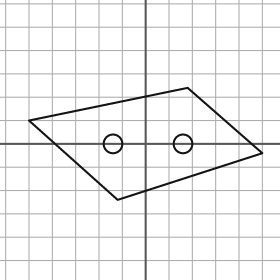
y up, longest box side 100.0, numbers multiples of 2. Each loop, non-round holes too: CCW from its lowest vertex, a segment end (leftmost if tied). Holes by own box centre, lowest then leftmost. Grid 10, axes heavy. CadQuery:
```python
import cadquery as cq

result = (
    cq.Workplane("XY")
    .moveTo(-12.0, -24.0)
    .lineTo(50.0, -4.0)
    .lineTo(18.0, 24.0)
    .lineTo(-50.0, 10.0)
    .close()
    .moveTo(-14.0, 0.0)
    .circle(4.0)
    .moveTo(16.0, 0.0)
    .circle(4.0)
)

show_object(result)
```